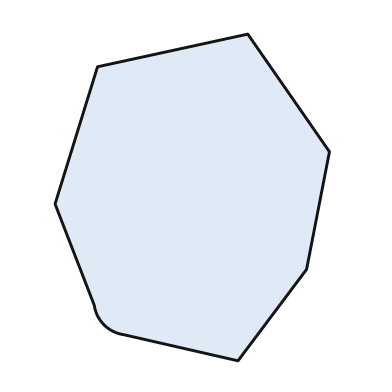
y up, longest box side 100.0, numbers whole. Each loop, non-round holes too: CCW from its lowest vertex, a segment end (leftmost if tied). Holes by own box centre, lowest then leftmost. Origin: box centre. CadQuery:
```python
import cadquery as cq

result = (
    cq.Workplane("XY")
    .moveTo(14.0, -50.0)
    .lineTo(35.0, -22.0)
    .lineTo(42.0, 14.0)
    .lineTo(17.0, 50.0)
    .lineTo(-29.0, 40.0)
    .lineTo(-42.0, -2.0)
    .lineTo(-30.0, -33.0)
    .threePointArc((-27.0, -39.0), (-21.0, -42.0))
    .close()
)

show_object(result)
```